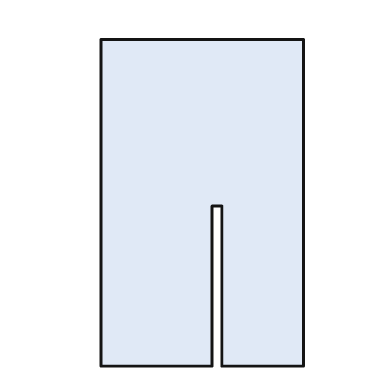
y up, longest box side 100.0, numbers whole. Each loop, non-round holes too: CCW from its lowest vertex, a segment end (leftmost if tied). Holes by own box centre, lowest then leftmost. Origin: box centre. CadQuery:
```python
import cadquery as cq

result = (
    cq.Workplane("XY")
    .moveTo(-31.0, -50.0)
    .lineTo(3.0, -50.0)
    .lineTo(3.0, -1.0)
    .lineTo(6.0, -1.0)
    .lineTo(6.0, -50.0)
    .lineTo(31.0, -50.0)
    .lineTo(31.0, 50.0)
    .lineTo(-31.0, 50.0)
    .close()
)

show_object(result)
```